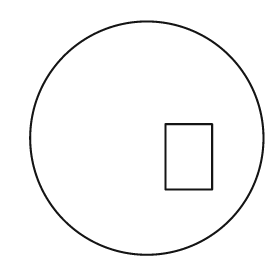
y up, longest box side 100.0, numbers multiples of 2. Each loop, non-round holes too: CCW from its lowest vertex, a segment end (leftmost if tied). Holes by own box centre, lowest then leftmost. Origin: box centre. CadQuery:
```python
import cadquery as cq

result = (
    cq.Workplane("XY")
    .moveTo(0.0, 0.0)
    .circle(50.0)
    .moveTo(8.0, -22.0)
    .lineTo(28.0, -22.0)
    .lineTo(28.0, 6.0)
    .lineTo(8.0, 6.0)
    .close()
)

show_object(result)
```